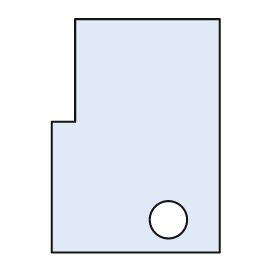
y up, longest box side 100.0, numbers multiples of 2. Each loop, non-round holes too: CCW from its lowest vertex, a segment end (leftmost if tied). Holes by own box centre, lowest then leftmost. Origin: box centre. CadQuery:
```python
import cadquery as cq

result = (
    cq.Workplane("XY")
    .moveTo(-36.0, -50.0)
    .lineTo(36.0, -50.0)
    .lineTo(36.0, 50.0)
    .lineTo(-26.0, 50.0)
    .lineTo(-26.0, 6.0)
    .lineTo(-36.0, 6.0)
    .close()
    .moveTo(14.0, -36.0)
    .circle(8.0)
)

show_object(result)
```